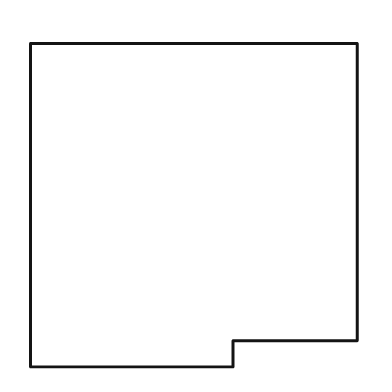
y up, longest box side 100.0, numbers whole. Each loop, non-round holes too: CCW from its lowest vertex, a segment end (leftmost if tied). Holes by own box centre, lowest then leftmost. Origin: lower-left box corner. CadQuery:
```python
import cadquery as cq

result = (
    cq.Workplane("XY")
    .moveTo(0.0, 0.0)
    .lineTo(62.0, 0.0)
    .lineTo(62.0, 8.0)
    .lineTo(100.0, 8.0)
    .lineTo(100.0, 99.0)
    .lineTo(0.0, 99.0)
    .close()
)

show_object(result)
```